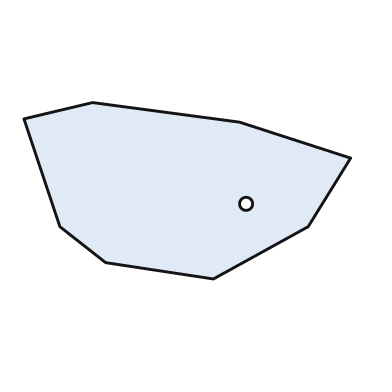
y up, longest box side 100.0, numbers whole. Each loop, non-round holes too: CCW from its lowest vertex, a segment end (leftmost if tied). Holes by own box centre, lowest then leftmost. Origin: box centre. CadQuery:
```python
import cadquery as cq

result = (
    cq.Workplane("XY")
    .moveTo(8.0, -27.0)
    .lineTo(37.0, -11.0)
    .lineTo(50.0, 10.0)
    .lineTo(16.0, 21.0)
    .lineTo(-29.0, 27.0)
    .lineTo(-50.0, 22.0)
    .lineTo(-39.0, -11.0)
    .lineTo(-25.0, -22.0)
    .close()
    .moveTo(18.0, -4.0)
    .circle(2.0)
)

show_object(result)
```